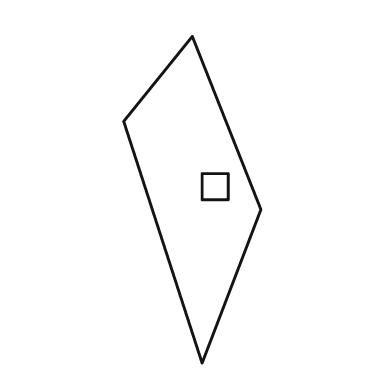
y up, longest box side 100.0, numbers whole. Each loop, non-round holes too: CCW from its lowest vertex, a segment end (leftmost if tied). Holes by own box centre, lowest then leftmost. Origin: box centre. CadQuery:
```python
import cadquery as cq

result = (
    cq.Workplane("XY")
    .moveTo(3.0, -50.0)
    .lineTo(21.0, -3.0)
    .lineTo(0.0, 50.0)
    .lineTo(-21.0, 24.0)
    .close()
    .moveTo(3.0, 0.0)
    .lineTo(11.0, 0.0)
    .lineTo(11.0, 8.0)
    .lineTo(3.0, 8.0)
    .close()
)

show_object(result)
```